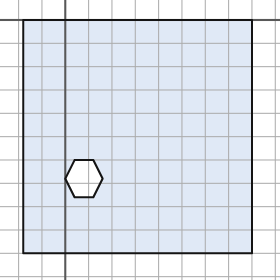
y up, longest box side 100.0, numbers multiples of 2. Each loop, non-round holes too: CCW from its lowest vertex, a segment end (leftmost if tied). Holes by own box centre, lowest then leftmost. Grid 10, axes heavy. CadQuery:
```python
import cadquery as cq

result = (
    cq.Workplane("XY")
    .moveTo(-18.0, -100.0)
    .lineTo(80.0, -100.0)
    .lineTo(80.0, 0.0)
    .lineTo(-18.0, 0.0)
    .close()
    .moveTo(4.0, -76.0)
    .lineTo(12.0, -76.0)
    .lineTo(16.0, -68.0)
    .lineTo(12.0, -60.0)
    .lineTo(4.0, -60.0)
    .lineTo(0.0, -68.0)
    .close()
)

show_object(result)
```